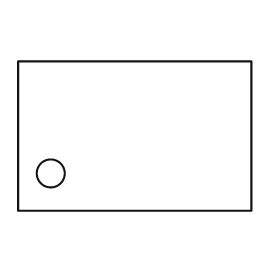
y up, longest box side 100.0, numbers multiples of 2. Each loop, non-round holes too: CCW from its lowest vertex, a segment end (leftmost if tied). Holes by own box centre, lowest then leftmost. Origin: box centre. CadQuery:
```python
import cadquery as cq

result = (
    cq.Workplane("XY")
    .moveTo(-50.0, -32.0)
    .lineTo(50.0, -32.0)
    .lineTo(50.0, 32.0)
    .lineTo(-50.0, 32.0)
    .close()
    .moveTo(-36.0, -16.0)
    .circle(6.0)
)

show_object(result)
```